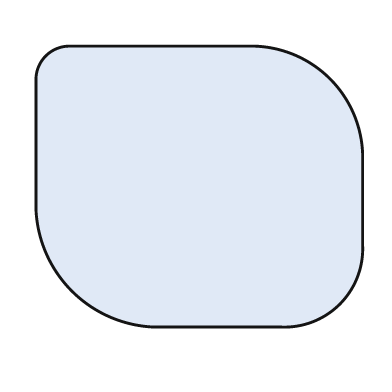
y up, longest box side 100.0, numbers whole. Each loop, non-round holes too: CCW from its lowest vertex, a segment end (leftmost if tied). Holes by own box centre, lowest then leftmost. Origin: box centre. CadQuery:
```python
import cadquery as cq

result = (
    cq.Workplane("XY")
    .moveTo(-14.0, -43.0)
    .lineTo(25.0, -43.0)
    .threePointArc((43.0, -36.0), (50.0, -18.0))
    .lineTo(50.0, 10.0)
    .threePointArc((40.0, 33.0), (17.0, 43.0))
    .lineTo(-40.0, 43.0)
    .threePointArc((-47.0, 40.0), (-50.0, 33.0))
    .lineTo(-50.0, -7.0)
    .threePointArc((-39.0, -32.0), (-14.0, -43.0))
    .close()
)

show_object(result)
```